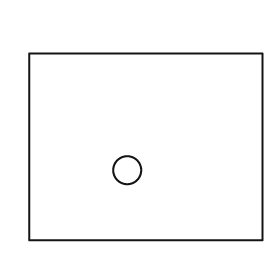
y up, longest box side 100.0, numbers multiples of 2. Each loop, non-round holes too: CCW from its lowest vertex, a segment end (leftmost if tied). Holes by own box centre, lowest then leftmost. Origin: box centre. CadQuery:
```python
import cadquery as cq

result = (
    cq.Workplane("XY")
    .moveTo(-50.0, -40.0)
    .lineTo(50.0, -40.0)
    .lineTo(50.0, 40.0)
    .lineTo(-50.0, 40.0)
    .close()
    .moveTo(-8.0, -10.0)
    .circle(6.0)
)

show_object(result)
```